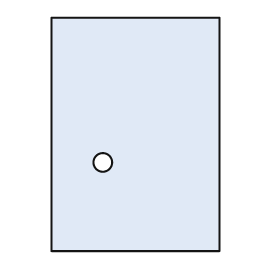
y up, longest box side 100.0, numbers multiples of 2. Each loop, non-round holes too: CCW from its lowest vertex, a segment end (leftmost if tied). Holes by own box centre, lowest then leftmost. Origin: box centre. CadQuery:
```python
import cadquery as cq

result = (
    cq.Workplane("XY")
    .moveTo(-36.0, -50.0)
    .lineTo(36.0, -50.0)
    .lineTo(36.0, 50.0)
    .lineTo(-36.0, 50.0)
    .close()
    .moveTo(-14.0, -12.0)
    .circle(4.0)
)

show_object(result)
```